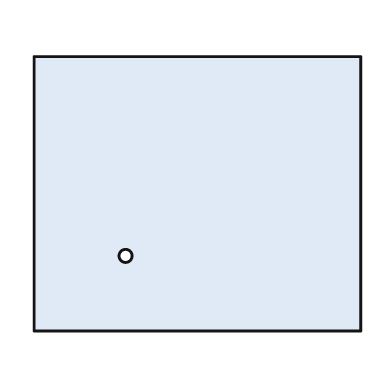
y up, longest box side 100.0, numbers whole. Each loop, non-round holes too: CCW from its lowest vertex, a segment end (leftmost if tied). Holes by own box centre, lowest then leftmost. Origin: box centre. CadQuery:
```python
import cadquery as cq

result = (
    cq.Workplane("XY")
    .moveTo(-50.0, -42.0)
    .lineTo(50.0, -42.0)
    .lineTo(50.0, 42.0)
    .lineTo(-50.0, 42.0)
    .close()
    .moveTo(-22.0, -19.0)
    .circle(2.0)
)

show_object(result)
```